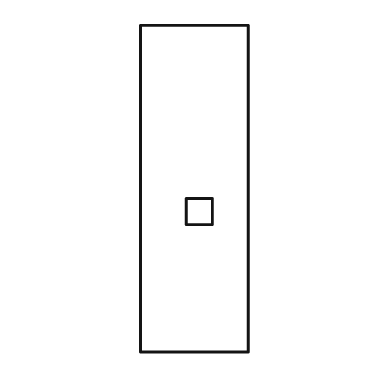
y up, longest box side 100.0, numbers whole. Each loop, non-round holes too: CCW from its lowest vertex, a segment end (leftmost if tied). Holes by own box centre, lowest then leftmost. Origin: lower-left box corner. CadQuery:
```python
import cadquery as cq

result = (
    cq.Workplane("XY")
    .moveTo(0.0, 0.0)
    .lineTo(33.0, 0.0)
    .lineTo(33.0, 100.0)
    .lineTo(0.0, 100.0)
    .close()
    .moveTo(14.0, 39.0)
    .lineTo(22.0, 39.0)
    .lineTo(22.0, 47.0)
    .lineTo(14.0, 47.0)
    .close()
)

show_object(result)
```